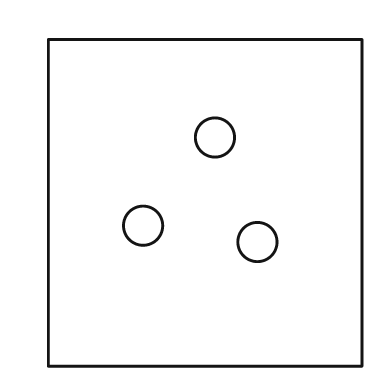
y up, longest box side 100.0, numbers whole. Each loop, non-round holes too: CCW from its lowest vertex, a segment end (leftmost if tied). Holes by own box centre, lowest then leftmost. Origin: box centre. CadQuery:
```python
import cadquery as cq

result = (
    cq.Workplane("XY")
    .moveTo(-48.0, -50.0)
    .lineTo(48.0, -50.0)
    .lineTo(48.0, 50.0)
    .lineTo(-48.0, 50.0)
    .close()
    .moveTo(16.0, -12.0)
    .circle(6.0)
    .moveTo(-19.0, -7.0)
    .circle(6.0)
    .moveTo(3.0, 20.0)
    .circle(6.0)
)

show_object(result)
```